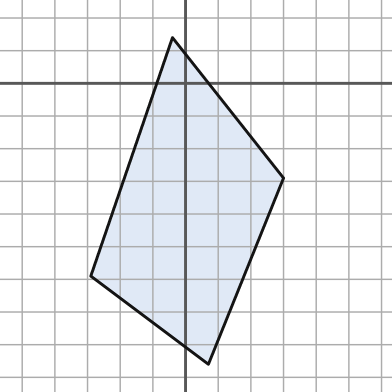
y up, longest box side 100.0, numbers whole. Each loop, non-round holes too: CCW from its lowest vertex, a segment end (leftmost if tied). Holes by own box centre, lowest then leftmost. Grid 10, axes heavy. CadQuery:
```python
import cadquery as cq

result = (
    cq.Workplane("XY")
    .moveTo(7.0, -86.0)
    .lineTo(30.0, -29.0)
    .lineTo(-4.0, 14.0)
    .lineTo(-29.0, -59.0)
    .close()
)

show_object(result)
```